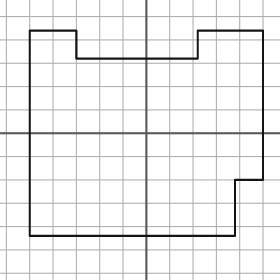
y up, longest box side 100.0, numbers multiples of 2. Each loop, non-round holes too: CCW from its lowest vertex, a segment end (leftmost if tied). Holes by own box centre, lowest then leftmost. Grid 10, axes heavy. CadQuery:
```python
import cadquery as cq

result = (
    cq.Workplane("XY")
    .moveTo(-50.0, -44.0)
    .lineTo(38.0, -44.0)
    .lineTo(38.0, -20.0)
    .lineTo(50.0, -20.0)
    .lineTo(50.0, 44.0)
    .lineTo(22.0, 44.0)
    .lineTo(22.0, 32.0)
    .lineTo(-30.0, 32.0)
    .lineTo(-30.0, 44.0)
    .lineTo(-50.0, 44.0)
    .close()
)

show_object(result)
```